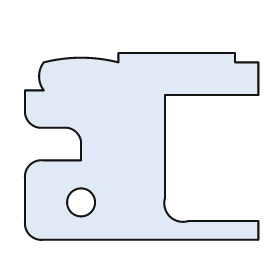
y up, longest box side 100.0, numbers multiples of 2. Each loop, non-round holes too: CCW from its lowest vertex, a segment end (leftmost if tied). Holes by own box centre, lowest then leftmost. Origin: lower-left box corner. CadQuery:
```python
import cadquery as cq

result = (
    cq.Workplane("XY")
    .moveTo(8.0, 0.0)
    .lineTo(100.0, 0.0)
    .lineTo(100.0, 8.0)
    .lineTo(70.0, 8.0)
    .threePointArc((62.0, 10.0), (60.0, 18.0))
    .lineTo(60.0, 62.0)
    .lineTo(100.0, 62.0)
    .lineTo(100.0, 76.0)
    .lineTo(90.0, 76.0)
    .lineTo(90.0, 80.0)
    .lineTo(40.0, 80.0)
    .lineTo(40.0, 76.0)
    .threePointArc((24.0, 78.0), (8.0, 76.0))
    .threePointArc((6.0, 70.0), (8.0, 64.0))
    .lineTo(0.0, 64.0)
    .lineTo(0.0, 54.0)
    .threePointArc((2.0, 50.0), (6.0, 48.0))
    .lineTo(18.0, 48.0)
    .threePointArc((22.0, 46.0), (24.0, 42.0))
    .lineTo(24.0, 34.0)
    .lineTo(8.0, 34.0)
    .threePointArc((2.0, 32.0), (0.0, 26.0))
    .lineTo(0.0, 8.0)
    .threePointArc((2.0, 2.0), (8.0, 0.0))
    .close()
    .moveTo(24.0, 16.0)
    .circle(6.0)
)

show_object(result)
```